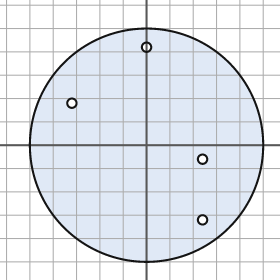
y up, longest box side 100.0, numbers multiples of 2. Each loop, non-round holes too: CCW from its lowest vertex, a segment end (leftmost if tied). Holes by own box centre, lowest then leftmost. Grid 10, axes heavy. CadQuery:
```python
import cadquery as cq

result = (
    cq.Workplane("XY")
    .moveTo(0.0, 0.0)
    .circle(50.0)
    .moveTo(24.0, -32.0)
    .circle(2.0)
    .moveTo(24.0, -6.0)
    .circle(2.0)
    .moveTo(-32.0, 18.0)
    .circle(2.0)
    .moveTo(0.0, 42.0)
    .circle(2.0)
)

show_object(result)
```